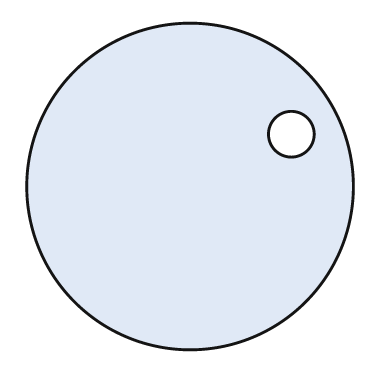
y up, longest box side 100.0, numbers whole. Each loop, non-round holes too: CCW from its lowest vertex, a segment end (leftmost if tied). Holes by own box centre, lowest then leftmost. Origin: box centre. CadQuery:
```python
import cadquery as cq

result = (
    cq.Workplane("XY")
    .moveTo(0.0, 0.0)
    .circle(50.0)
    .moveTo(31.0, 16.0)
    .circle(7.0)
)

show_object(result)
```